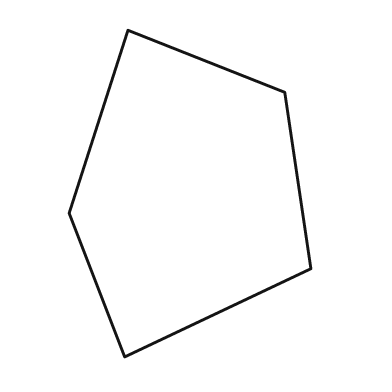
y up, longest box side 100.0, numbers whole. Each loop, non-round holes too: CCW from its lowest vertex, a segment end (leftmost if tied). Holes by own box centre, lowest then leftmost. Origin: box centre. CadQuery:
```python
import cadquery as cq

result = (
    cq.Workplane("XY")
    .moveTo(-20.0, -50.0)
    .lineTo(37.0, -23.0)
    .lineTo(29.0, 31.0)
    .lineTo(-19.0, 50.0)
    .lineTo(-37.0, -6.0)
    .close()
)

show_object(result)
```